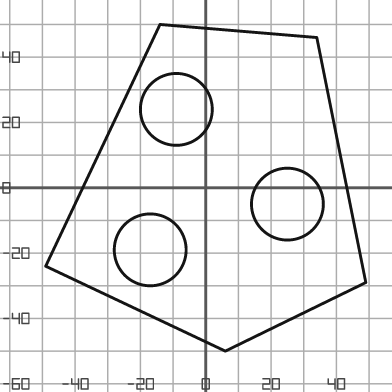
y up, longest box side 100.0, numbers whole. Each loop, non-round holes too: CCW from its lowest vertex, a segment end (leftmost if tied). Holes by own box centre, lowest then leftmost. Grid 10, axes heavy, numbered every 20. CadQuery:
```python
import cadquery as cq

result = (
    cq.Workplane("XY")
    .moveTo(6.0, -50.0)
    .lineTo(49.0, -29.0)
    .lineTo(34.0, 46.0)
    .lineTo(-14.0, 50.0)
    .lineTo(-49.0, -24.0)
    .close()
    .moveTo(-17.0, -19.0)
    .circle(11.0)
    .moveTo(25.0, -5.0)
    .circle(11.0)
    .moveTo(-9.0, 24.0)
    .circle(11.0)
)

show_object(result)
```